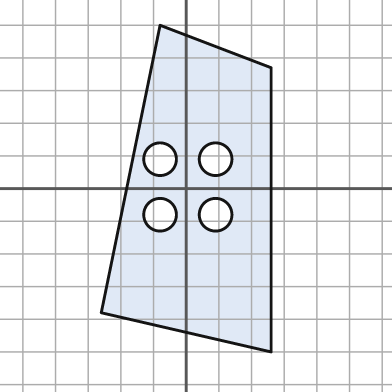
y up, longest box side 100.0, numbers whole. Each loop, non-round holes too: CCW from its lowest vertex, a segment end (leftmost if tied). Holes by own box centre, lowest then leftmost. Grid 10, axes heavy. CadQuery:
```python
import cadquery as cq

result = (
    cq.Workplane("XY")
    .moveTo(26.0, -50.0)
    .lineTo(26.0, 37.0)
    .lineTo(-8.0, 50.0)
    .lineTo(-26.0, -38.0)
    .close()
    .moveTo(-8.0, -8.0)
    .circle(5.0)
    .moveTo(9.0, -8.0)
    .circle(5.0)
    .moveTo(-8.0, 9.0)
    .circle(5.0)
    .moveTo(9.0, 9.0)
    .circle(5.0)
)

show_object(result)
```